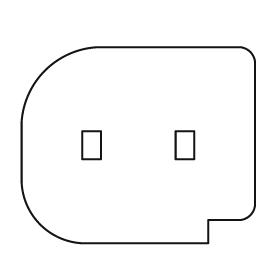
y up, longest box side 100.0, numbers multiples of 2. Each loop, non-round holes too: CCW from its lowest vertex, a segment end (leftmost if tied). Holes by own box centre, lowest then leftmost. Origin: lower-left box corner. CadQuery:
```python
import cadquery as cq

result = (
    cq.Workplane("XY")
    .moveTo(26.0, 0.0)
    .lineTo(80.0, 0.0)
    .lineTo(80.0, 10.0)
    .lineTo(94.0, 10.0)
    .threePointArc((98.0, 12.0), (100.0, 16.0))
    .lineTo(100.0, 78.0)
    .threePointArc((98.0, 82.0), (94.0, 84.0))
    .lineTo(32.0, 84.0)
    .threePointArc((10.0, 74.0), (0.0, 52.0))
    .lineTo(0.0, 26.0)
    .threePointArc((8.0, 8.0), (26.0, 0.0))
    .close()
    .moveTo(26.0, 36.0)
    .lineTo(34.0, 36.0)
    .lineTo(34.0, 48.0)
    .lineTo(26.0, 48.0)
    .close()
    .moveTo(66.0, 36.0)
    .lineTo(74.0, 36.0)
    .lineTo(74.0, 48.0)
    .lineTo(66.0, 48.0)
    .close()
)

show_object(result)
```